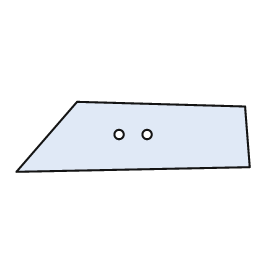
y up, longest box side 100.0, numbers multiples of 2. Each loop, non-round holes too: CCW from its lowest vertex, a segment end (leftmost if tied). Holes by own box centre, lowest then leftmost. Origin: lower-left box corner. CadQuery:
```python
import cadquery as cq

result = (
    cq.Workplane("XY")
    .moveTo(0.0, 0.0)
    .lineTo(100.0, 2.0)
    .lineTo(98.0, 28.0)
    .lineTo(26.0, 30.0)
    .close()
    .moveTo(44.0, 16.0)
    .circle(2.0)
    .moveTo(56.0, 16.0)
    .circle(2.0)
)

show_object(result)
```